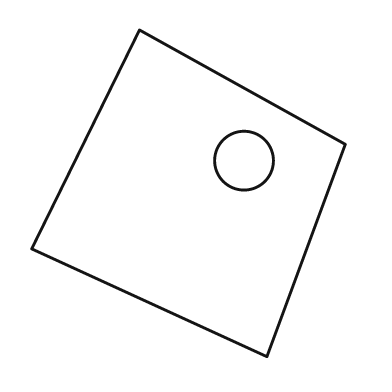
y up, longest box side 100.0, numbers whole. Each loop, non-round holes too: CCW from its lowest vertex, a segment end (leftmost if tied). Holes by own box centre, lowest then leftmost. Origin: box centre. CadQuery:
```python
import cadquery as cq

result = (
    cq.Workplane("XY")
    .moveTo(24.0, -50.0)
    .lineTo(48.0, 15.0)
    .lineTo(-15.0, 50.0)
    .lineTo(-48.0, -17.0)
    .close()
    .moveTo(17.0, 10.0)
    .circle(9.0)
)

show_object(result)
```